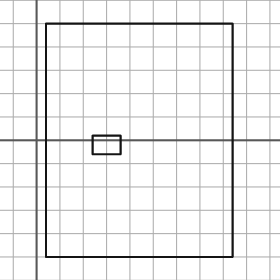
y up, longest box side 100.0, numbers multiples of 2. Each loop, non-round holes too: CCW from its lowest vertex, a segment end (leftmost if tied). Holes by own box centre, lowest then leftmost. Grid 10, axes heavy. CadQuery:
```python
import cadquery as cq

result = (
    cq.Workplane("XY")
    .moveTo(4.0, -50.0)
    .lineTo(84.0, -50.0)
    .lineTo(84.0, 50.0)
    .lineTo(4.0, 50.0)
    .close()
    .moveTo(24.0, -6.0)
    .lineTo(36.0, -6.0)
    .lineTo(36.0, 2.0)
    .lineTo(24.0, 2.0)
    .close()
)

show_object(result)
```